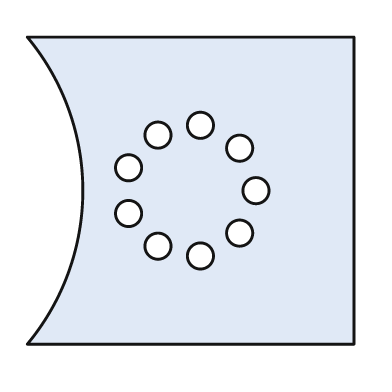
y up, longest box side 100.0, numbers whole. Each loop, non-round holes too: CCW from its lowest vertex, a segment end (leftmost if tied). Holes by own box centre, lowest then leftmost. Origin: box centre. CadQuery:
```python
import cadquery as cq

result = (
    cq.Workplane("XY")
    .moveTo(-50.0, -47.0)
    .lineTo(50.0, -47.0)
    .lineTo(50.0, 47.0)
    .lineTo(-50.0, 47.0)
    .threePointArc((-33.0, 0.0), (-50.0, -47.0))
    .close()
    .moveTo(3.0, -20.0)
    .circle(4.0)
    .moveTo(-10.0, -17.0)
    .circle(4.0)
    .moveTo(15.0, -13.0)
    .circle(4.0)
    .moveTo(-19.0, -7.0)
    .circle(4.0)
    .moveTo(20.0, 0.0)
    .circle(4.0)
    .moveTo(-19.0, 7.0)
    .circle(4.0)
    .moveTo(15.0, 13.0)
    .circle(4.0)
    .moveTo(-10.0, 17.0)
    .circle(4.0)
    .moveTo(3.0, 20.0)
    .circle(4.0)
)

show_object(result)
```